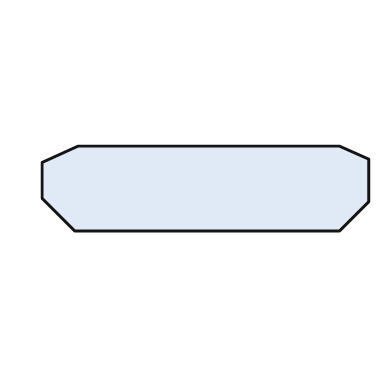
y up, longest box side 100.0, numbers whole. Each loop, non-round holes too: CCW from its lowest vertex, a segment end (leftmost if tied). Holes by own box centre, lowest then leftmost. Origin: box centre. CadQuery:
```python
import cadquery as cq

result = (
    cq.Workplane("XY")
    .moveTo(-40.0, -13.0)
    .lineTo(41.0, -13.0)
    .lineTo(50.0, -4.0)
    .lineTo(50.0, 9.0)
    .lineTo(41.0, 13.0)
    .lineTo(-39.0, 13.0)
    .lineTo(-50.0, 8.0)
    .lineTo(-50.0, -3.0)
    .close()
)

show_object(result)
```